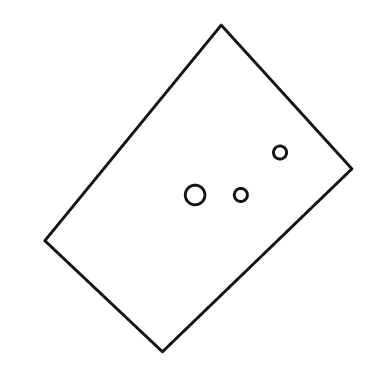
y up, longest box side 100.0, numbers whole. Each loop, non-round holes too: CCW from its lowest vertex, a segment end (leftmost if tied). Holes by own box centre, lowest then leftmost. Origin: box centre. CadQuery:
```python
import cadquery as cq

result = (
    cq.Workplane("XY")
    .moveTo(-11.0, -50.0)
    .lineTo(47.0, 6.0)
    .lineTo(7.0, 50.0)
    .lineTo(-47.0, -16.0)
    .close()
    .moveTo(-1.0, -2.0)
    .circle(3.0)
    .moveTo(13.0, -2.0)
    .circle(2.0)
    .moveTo(25.0, 11.0)
    .circle(2.0)
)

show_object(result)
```